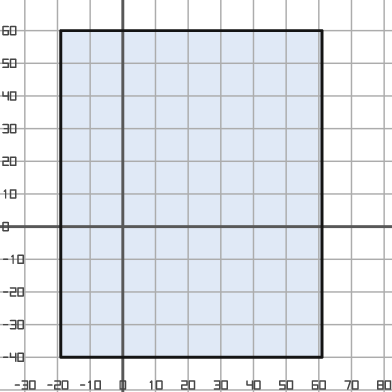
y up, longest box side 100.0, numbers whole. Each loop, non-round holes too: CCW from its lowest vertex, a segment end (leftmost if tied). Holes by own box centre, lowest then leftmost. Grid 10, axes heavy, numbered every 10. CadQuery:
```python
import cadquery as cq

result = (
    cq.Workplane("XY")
    .moveTo(-19.0, -40.0)
    .lineTo(61.0, -40.0)
    .lineTo(61.0, 60.0)
    .lineTo(-19.0, 60.0)
    .close()
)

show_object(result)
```